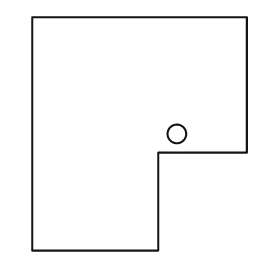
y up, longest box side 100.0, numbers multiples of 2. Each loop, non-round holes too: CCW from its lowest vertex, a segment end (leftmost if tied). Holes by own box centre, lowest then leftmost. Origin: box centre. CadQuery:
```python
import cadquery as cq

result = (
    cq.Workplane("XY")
    .moveTo(-46.0, -50.0)
    .lineTo(8.0, -50.0)
    .lineTo(8.0, -8.0)
    .lineTo(46.0, -8.0)
    .lineTo(46.0, 50.0)
    .lineTo(-46.0, 50.0)
    .close()
    .moveTo(16.0, 0.0)
    .circle(4.0)
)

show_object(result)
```